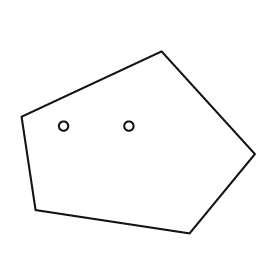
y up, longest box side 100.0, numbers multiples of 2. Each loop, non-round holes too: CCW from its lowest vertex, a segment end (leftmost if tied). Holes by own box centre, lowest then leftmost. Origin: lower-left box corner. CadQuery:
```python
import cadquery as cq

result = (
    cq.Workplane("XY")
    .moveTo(72.0, 0.0)
    .lineTo(100.0, 34.0)
    .lineTo(60.0, 78.0)
    .lineTo(0.0, 50.0)
    .lineTo(6.0, 10.0)
    .close()
    .moveTo(18.0, 46.0)
    .circle(2.0)
    .moveTo(46.0, 46.0)
    .circle(2.0)
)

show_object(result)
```